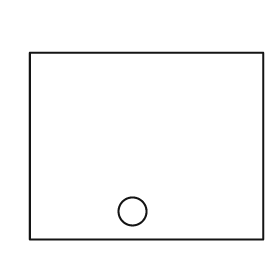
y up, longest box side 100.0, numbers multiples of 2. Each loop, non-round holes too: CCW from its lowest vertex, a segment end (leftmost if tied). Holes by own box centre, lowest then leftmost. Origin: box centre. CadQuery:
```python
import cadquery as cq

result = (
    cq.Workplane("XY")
    .moveTo(-50.0, -40.0)
    .lineTo(50.0, -40.0)
    .lineTo(50.0, 40.0)
    .lineTo(-50.0, 40.0)
    .close()
    .moveTo(-6.0, -28.0)
    .circle(6.0)
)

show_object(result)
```